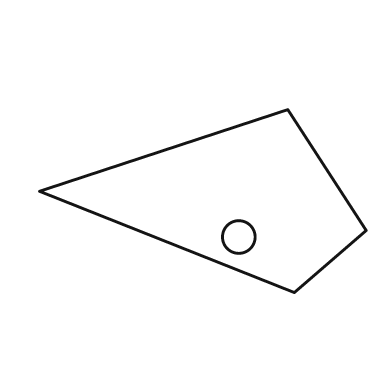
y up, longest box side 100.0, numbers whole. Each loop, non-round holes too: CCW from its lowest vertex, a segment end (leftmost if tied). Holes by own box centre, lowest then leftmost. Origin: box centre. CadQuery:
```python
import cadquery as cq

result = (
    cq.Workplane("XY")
    .moveTo(28.0, -28.0)
    .lineTo(50.0, -9.0)
    .lineTo(26.0, 28.0)
    .lineTo(-50.0, 3.0)
    .close()
    .moveTo(11.0, -11.0)
    .circle(5.0)
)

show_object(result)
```